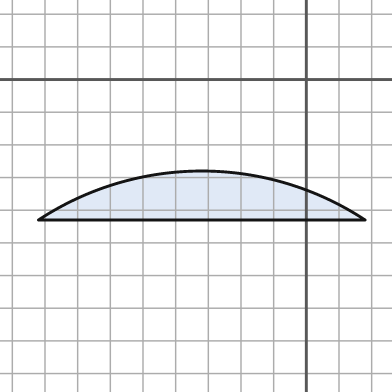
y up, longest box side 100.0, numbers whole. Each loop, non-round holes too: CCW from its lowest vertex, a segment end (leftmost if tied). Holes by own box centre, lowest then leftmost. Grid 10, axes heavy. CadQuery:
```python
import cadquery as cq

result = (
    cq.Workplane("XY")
    .moveTo(-82.0, -43.0)
    .lineTo(18.0, -43.0)
    .threePointArc((-32.0, -28.0), (-82.0, -43.0))
    .close()
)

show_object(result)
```